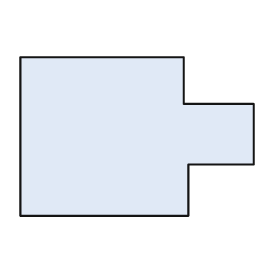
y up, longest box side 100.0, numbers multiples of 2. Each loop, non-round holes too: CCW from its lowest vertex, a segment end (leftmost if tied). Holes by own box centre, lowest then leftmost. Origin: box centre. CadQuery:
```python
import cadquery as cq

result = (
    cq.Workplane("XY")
    .moveTo(-50.0, -34.0)
    .lineTo(22.0, -34.0)
    .lineTo(22.0, -12.0)
    .lineTo(50.0, -12.0)
    .lineTo(50.0, 14.0)
    .lineTo(20.0, 14.0)
    .lineTo(20.0, 34.0)
    .lineTo(-50.0, 34.0)
    .close()
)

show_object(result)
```